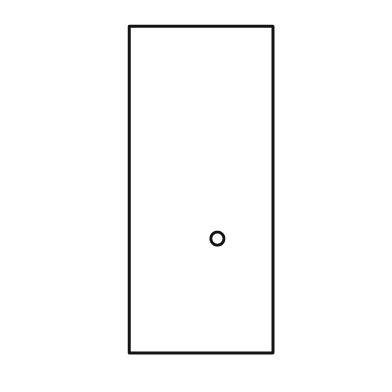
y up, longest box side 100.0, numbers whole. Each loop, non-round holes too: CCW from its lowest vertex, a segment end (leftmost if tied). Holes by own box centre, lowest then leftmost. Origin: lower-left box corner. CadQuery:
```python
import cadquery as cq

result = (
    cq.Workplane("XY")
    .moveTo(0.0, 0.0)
    .lineTo(44.0, 0.0)
    .lineTo(44.0, 100.0)
    .lineTo(0.0, 100.0)
    .close()
    .moveTo(27.0, 35.0)
    .circle(2.0)
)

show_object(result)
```